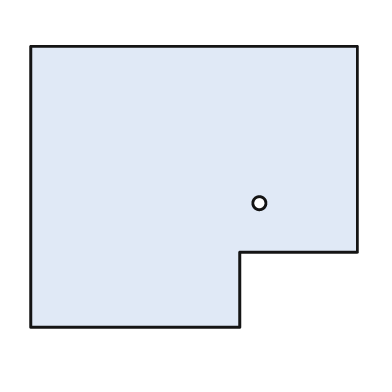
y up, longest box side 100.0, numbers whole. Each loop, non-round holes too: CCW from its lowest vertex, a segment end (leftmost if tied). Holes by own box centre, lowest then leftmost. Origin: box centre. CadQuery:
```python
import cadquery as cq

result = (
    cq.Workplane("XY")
    .moveTo(-50.0, -43.0)
    .lineTo(14.0, -43.0)
    .lineTo(14.0, -20.0)
    .lineTo(50.0, -20.0)
    .lineTo(50.0, 43.0)
    .lineTo(-50.0, 43.0)
    .close()
    .moveTo(20.0, -5.0)
    .circle(2.0)
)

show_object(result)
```